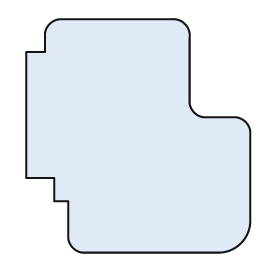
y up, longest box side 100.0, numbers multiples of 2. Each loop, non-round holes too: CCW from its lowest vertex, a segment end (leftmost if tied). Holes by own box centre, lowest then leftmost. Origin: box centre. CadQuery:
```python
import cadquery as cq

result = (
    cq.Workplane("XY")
    .moveTo(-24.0, -50.0)
    .lineTo(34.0, -50.0)
    .threePointArc((44.0, -46.0), (48.0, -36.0))
    .lineTo(48.0, 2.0)
    .threePointArc((46.0, 6.0), (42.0, 8.0))
    .lineTo(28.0, 8.0)
    .threePointArc((24.0, 10.0), (22.0, 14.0))
    .lineTo(22.0, 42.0)
    .threePointArc((20.0, 48.0), (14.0, 50.0))
    .lineTo(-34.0, 50.0)
    .threePointArc((-38.0, 48.0), (-40.0, 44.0))
    .lineTo(-40.0, 36.0)
    .lineTo(-48.0, 36.0)
    .lineTo(-48.0, -18.0)
    .lineTo(-36.0, -18.0)
    .lineTo(-36.0, -28.0)
    .lineTo(-30.0, -28.0)
    .lineTo(-30.0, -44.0)
    .threePointArc((-28.0, -48.0), (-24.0, -50.0))
    .close()
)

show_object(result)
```